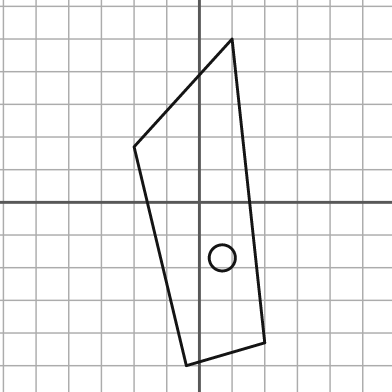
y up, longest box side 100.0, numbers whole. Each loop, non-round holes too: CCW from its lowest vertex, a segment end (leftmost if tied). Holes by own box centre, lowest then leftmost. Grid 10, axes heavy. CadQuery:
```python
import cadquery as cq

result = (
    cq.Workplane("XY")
    .moveTo(-4.0, -50.0)
    .lineTo(20.0, -43.0)
    .lineTo(10.0, 50.0)
    .lineTo(-20.0, 17.0)
    .close()
    .moveTo(7.0, -17.0)
    .circle(4.0)
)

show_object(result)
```